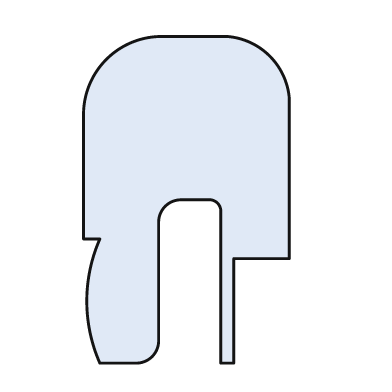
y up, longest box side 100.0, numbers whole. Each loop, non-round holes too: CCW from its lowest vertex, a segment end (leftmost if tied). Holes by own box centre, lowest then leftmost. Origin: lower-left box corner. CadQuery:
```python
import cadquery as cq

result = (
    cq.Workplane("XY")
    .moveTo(5.0, 0.0)
    .lineTo(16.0, 0.0)
    .threePointArc((21.0, 2.0), (23.0, 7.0))
    .lineTo(23.0, 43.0)
    .threePointArc((25.0, 48.0), (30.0, 50.0))
    .lineTo(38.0, 50.0)
    .threePointArc((41.0, 49.0), (42.0, 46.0))
    .lineTo(42.0, 0.0)
    .lineTo(46.0, 0.0)
    .lineTo(46.0, 32.0)
    .lineTo(63.0, 32.0)
    .lineTo(63.0, 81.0)
    .threePointArc((57.0, 94.0), (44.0, 100.0))
    .lineTo(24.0, 100.0)
    .threePointArc((7.0, 93.0), (0.0, 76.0))
    .lineTo(0.0, 38.0)
    .lineTo(5.0, 38.0)
    .threePointArc((1.0, 19.0), (5.0, 0.0))
    .close()
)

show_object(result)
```